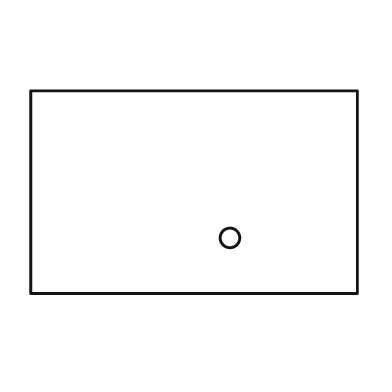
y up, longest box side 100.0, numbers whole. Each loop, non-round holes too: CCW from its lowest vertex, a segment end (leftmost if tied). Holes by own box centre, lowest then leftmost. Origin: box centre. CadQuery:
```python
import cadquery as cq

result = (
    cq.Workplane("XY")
    .moveTo(-50.0, -31.0)
    .lineTo(50.0, -31.0)
    .lineTo(50.0, 31.0)
    .lineTo(-50.0, 31.0)
    .close()
    .moveTo(11.0, -14.0)
    .circle(3.0)
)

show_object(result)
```